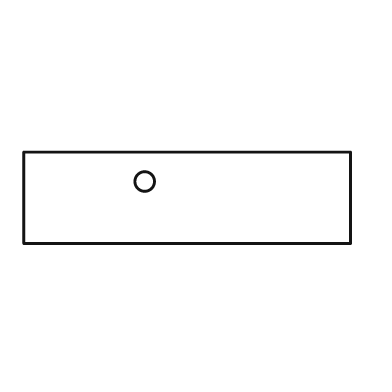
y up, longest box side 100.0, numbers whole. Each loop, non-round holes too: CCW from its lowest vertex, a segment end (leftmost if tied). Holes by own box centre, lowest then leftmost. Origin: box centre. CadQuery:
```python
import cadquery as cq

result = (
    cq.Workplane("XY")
    .moveTo(-50.0, -14.0)
    .lineTo(50.0, -14.0)
    .lineTo(50.0, 14.0)
    .lineTo(-50.0, 14.0)
    .close()
    .moveTo(-13.0, 5.0)
    .circle(3.0)
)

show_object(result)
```